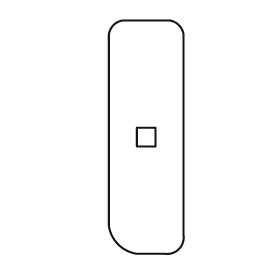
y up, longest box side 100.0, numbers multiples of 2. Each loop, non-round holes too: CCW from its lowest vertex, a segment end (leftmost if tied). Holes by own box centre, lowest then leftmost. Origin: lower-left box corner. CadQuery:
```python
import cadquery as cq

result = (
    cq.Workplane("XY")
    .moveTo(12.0, 0.0)
    .lineTo(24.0, 0.0)
    .threePointArc((30.0, 2.0), (32.0, 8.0))
    .lineTo(32.0, 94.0)
    .threePointArc((30.0, 98.0), (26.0, 100.0))
    .lineTo(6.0, 100.0)
    .threePointArc((2.0, 98.0), (0.0, 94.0))
    .lineTo(0.0, 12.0)
    .threePointArc((4.0, 4.0), (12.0, 0.0))
    .close()
    .moveTo(12.0, 46.0)
    .lineTo(20.0, 46.0)
    .lineTo(20.0, 54.0)
    .lineTo(12.0, 54.0)
    .close()
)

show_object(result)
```